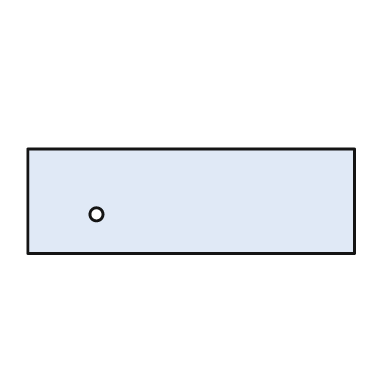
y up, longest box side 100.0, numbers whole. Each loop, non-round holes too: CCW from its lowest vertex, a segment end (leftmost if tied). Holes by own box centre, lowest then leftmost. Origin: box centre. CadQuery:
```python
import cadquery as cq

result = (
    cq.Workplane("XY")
    .moveTo(-50.0, -16.0)
    .lineTo(50.0, -16.0)
    .lineTo(50.0, 16.0)
    .lineTo(-50.0, 16.0)
    .close()
    .moveTo(-29.0, -4.0)
    .circle(2.0)
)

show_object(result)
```